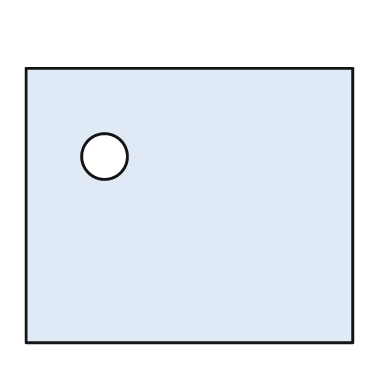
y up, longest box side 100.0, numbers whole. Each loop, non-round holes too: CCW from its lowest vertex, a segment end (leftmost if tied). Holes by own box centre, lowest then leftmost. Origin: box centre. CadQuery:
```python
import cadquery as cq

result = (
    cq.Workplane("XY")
    .moveTo(-50.0, -42.0)
    .lineTo(50.0, -42.0)
    .lineTo(50.0, 42.0)
    .lineTo(-50.0, 42.0)
    .close()
    .moveTo(-26.0, 15.0)
    .circle(7.0)
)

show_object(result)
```